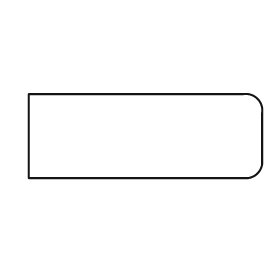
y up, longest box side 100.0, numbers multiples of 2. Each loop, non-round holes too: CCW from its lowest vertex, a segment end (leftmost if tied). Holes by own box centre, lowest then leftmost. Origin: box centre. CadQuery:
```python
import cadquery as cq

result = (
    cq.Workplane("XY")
    .moveTo(-50.0, -18.0)
    .lineTo(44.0, -18.0)
    .threePointArc((48.0, -16.0), (50.0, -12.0))
    .lineTo(50.0, 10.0)
    .threePointArc((48.0, 16.0), (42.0, 18.0))
    .lineTo(-50.0, 18.0)
    .close()
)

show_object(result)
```